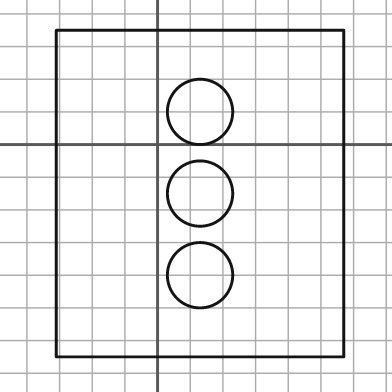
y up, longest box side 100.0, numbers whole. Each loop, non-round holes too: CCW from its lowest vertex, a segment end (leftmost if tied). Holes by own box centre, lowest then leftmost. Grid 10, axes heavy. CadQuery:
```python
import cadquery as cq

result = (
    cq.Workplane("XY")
    .moveTo(-31.0, -65.0)
    .lineTo(57.0, -65.0)
    .lineTo(57.0, 35.0)
    .lineTo(-31.0, 35.0)
    .close()
    .moveTo(13.0, -40.0)
    .circle(10.0)
    .moveTo(13.0, -15.0)
    .circle(10.0)
    .moveTo(13.0, 10.0)
    .circle(10.0)
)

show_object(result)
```